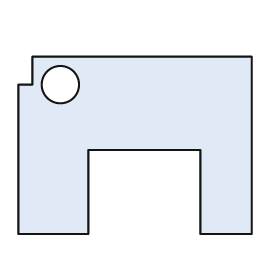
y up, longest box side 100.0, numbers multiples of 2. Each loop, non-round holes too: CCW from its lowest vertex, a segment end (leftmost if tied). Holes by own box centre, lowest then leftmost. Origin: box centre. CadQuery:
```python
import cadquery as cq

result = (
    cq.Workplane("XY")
    .moveTo(-50.0, -38.0)
    .lineTo(-20.0, -38.0)
    .lineTo(-20.0, -2.0)
    .lineTo(28.0, -2.0)
    .lineTo(28.0, -38.0)
    .lineTo(50.0, -38.0)
    .lineTo(50.0, 38.0)
    .lineTo(-44.0, 38.0)
    .lineTo(-44.0, 26.0)
    .lineTo(-50.0, 26.0)
    .close()
    .moveTo(-32.0, 26.0)
    .circle(8.0)
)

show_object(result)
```